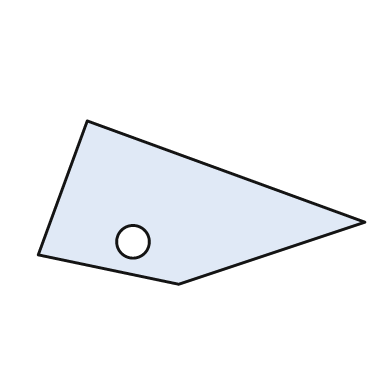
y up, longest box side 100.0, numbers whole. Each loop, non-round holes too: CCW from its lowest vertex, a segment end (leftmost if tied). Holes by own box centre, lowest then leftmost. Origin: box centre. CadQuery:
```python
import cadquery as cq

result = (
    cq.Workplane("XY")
    .moveTo(-7.0, -25.0)
    .lineTo(50.0, -6.0)
    .lineTo(-35.0, 25.0)
    .lineTo(-50.0, -16.0)
    .close()
    .moveTo(-21.0, -12.0)
    .circle(5.0)
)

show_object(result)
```